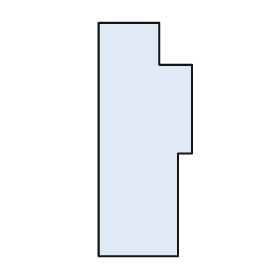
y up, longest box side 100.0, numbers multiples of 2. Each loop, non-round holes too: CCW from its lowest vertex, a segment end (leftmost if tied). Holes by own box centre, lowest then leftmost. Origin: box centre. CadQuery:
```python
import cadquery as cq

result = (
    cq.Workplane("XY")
    .moveTo(-20.0, -50.0)
    .lineTo(14.0, -50.0)
    .lineTo(14.0, -6.0)
    .lineTo(20.0, -6.0)
    .lineTo(20.0, 32.0)
    .lineTo(6.0, 32.0)
    .lineTo(6.0, 50.0)
    .lineTo(-20.0, 50.0)
    .close()
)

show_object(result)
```